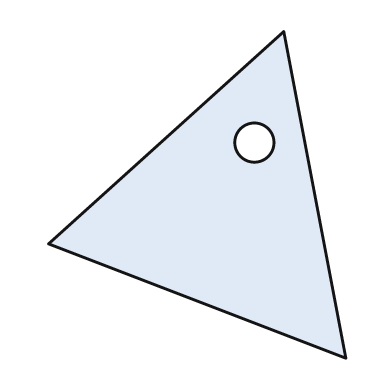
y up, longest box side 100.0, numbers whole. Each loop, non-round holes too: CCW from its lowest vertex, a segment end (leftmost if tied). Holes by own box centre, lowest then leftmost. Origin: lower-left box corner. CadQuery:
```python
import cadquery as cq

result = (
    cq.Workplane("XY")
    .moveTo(91.0, 0.0)
    .lineTo(72.0, 100.0)
    .lineTo(0.0, 35.0)
    .close()
    .moveTo(63.0, 66.0)
    .circle(6.0)
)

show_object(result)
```